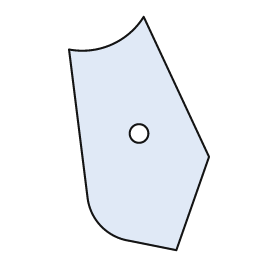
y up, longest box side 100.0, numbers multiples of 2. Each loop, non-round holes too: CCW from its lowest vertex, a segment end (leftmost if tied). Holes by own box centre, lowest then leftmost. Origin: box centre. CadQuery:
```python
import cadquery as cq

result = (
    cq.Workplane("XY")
    .moveTo(16.0, -50.0)
    .lineTo(30.0, -10.0)
    .lineTo(2.0, 50.0)
    .threePointArc((-12.0, 38.0), (-30.0, 36.0))
    .lineTo(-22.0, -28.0)
    .threePointArc((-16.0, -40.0), (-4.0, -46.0))
    .close()
    .moveTo(0.0, 0.0)
    .circle(4.0)
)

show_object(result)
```